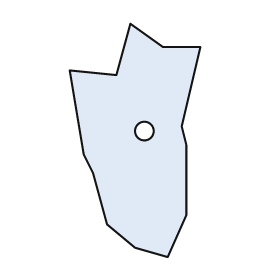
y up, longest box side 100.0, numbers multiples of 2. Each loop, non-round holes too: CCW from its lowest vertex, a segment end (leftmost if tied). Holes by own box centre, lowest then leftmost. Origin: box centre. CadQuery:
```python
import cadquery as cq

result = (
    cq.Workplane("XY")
    .moveTo(14.0, -50.0)
    .lineTo(22.0, -32.0)
    .lineTo(22.0, -2.0)
    .lineTo(20.0, 6.0)
    .lineTo(28.0, 40.0)
    .lineTo(12.0, 40.0)
    .lineTo(-2.0, 50.0)
    .lineTo(-8.0, 28.0)
    .lineTo(-28.0, 30.0)
    .lineTo(-22.0, -6.0)
    .lineTo(-18.0, -14.0)
    .lineTo(-12.0, -36.0)
    .lineTo(0.0, -46.0)
    .close()
    .moveTo(4.0, 4.0)
    .circle(4.0)
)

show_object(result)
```